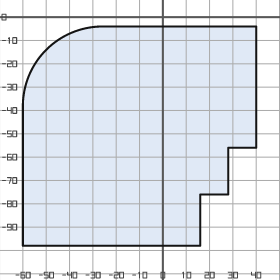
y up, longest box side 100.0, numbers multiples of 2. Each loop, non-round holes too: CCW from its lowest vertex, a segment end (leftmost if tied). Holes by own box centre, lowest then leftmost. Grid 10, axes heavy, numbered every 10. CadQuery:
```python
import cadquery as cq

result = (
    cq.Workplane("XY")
    .moveTo(-60.0, -98.0)
    .lineTo(16.0, -98.0)
    .lineTo(16.0, -76.0)
    .lineTo(28.0, -76.0)
    .lineTo(28.0, -56.0)
    .lineTo(40.0, -56.0)
    .lineTo(40.0, -4.0)
    .lineTo(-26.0, -4.0)
    .threePointArc((-50.0, -14.0), (-60.0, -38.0))
    .close()
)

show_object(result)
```